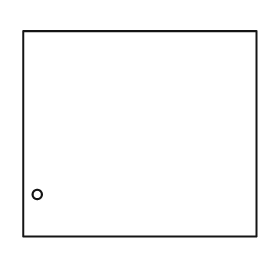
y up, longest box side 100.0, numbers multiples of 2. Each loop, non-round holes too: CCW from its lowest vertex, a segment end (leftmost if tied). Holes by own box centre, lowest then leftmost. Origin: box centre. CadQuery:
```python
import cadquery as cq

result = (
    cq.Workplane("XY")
    .moveTo(-50.0, -44.0)
    .lineTo(50.0, -44.0)
    .lineTo(50.0, 44.0)
    .lineTo(-50.0, 44.0)
    .close()
    .moveTo(-44.0, -26.0)
    .circle(2.0)
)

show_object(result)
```